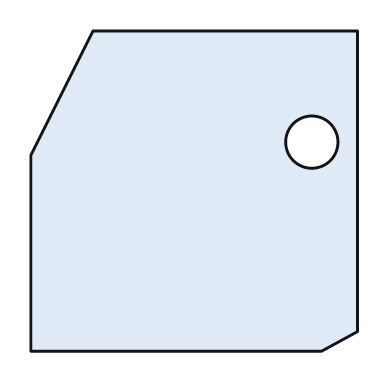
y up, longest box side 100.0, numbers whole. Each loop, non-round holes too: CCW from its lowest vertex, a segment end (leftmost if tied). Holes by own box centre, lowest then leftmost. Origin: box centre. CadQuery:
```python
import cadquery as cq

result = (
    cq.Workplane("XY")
    .moveTo(-50.0, -49.0)
    .lineTo(39.0, -49.0)
    .lineTo(50.0, -43.0)
    .lineTo(50.0, 49.0)
    .lineTo(-31.0, 49.0)
    .lineTo(-50.0, 11.0)
    .close()
    .moveTo(36.0, 15.0)
    .circle(8.0)
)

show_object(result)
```